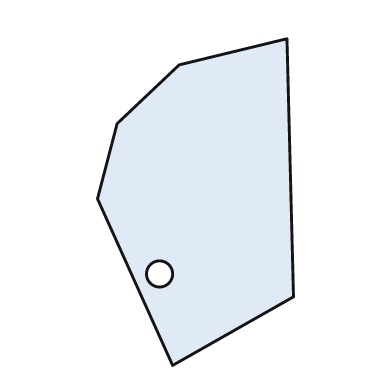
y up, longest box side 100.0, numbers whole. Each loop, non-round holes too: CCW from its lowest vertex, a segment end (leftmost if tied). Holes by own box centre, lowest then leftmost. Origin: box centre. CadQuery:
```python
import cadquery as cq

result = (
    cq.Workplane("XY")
    .moveTo(-7.0, -50.0)
    .lineTo(30.0, -29.0)
    .lineTo(28.0, 50.0)
    .lineTo(-5.0, 42.0)
    .lineTo(-24.0, 24.0)
    .lineTo(-30.0, 1.0)
    .close()
    .moveTo(-11.0, -22.0)
    .circle(4.0)
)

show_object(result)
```